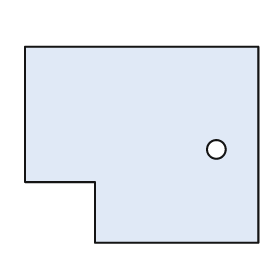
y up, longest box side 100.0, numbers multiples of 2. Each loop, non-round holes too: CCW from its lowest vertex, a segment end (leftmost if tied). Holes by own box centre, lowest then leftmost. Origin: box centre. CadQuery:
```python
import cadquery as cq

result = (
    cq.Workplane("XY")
    .moveTo(-20.0, -42.0)
    .lineTo(50.0, -42.0)
    .lineTo(50.0, 42.0)
    .lineTo(-50.0, 42.0)
    .lineTo(-50.0, -16.0)
    .lineTo(-20.0, -16.0)
    .close()
    .moveTo(32.0, -2.0)
    .circle(4.0)
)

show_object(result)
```